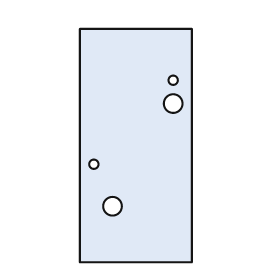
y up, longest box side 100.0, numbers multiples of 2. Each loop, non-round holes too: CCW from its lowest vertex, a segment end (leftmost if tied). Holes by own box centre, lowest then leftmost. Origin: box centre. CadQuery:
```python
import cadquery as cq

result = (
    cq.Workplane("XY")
    .moveTo(-24.0, -50.0)
    .lineTo(24.0, -50.0)
    .lineTo(24.0, 50.0)
    .lineTo(-24.0, 50.0)
    .close()
    .moveTo(-10.0, -26.0)
    .circle(4.0)
    .moveTo(-18.0, -8.0)
    .circle(2.0)
    .moveTo(16.0, 18.0)
    .circle(4.0)
    .moveTo(16.0, 28.0)
    .circle(2.0)
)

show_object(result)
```